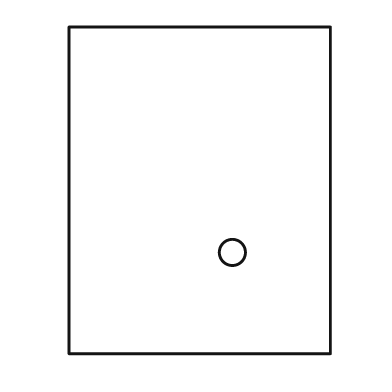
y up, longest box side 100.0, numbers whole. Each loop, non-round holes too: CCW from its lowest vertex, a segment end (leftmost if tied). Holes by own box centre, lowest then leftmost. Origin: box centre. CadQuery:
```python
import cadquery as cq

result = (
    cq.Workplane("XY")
    .moveTo(-40.0, -50.0)
    .lineTo(40.0, -50.0)
    .lineTo(40.0, 50.0)
    .lineTo(-40.0, 50.0)
    .close()
    .moveTo(10.0, -19.0)
    .circle(4.0)
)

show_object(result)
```